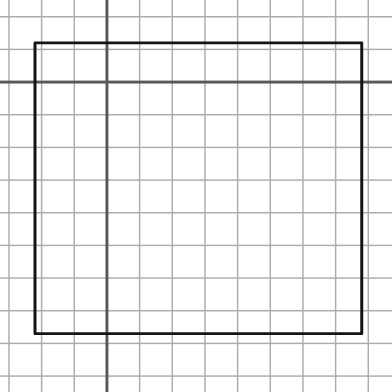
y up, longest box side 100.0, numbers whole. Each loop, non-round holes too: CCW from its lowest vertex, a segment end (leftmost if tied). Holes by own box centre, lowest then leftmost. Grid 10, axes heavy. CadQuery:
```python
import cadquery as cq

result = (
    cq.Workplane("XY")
    .moveTo(-22.0, -77.0)
    .lineTo(78.0, -77.0)
    .lineTo(78.0, 12.0)
    .lineTo(-22.0, 12.0)
    .close()
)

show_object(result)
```